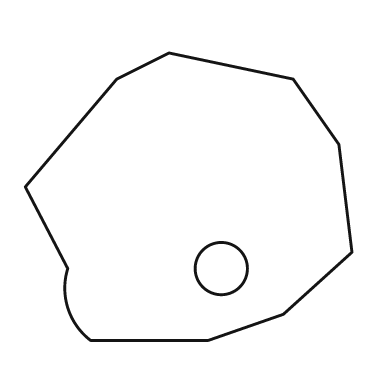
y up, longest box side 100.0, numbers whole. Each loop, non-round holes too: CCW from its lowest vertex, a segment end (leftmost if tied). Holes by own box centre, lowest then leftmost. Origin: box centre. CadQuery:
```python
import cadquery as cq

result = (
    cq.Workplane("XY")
    .moveTo(-30.0, -44.0)
    .lineTo(6.0, -44.0)
    .lineTo(29.0, -36.0)
    .lineTo(50.0, -17.0)
    .lineTo(46.0, 16.0)
    .lineTo(32.0, 36.0)
    .lineTo(-6.0, 44.0)
    .lineTo(-22.0, 36.0)
    .lineTo(-50.0, 3.0)
    .lineTo(-37.0, -22.0)
    .threePointArc((-37.0, -34.0), (-30.0, -44.0))
    .close()
    .moveTo(10.0, -22.0)
    .circle(8.0)
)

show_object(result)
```